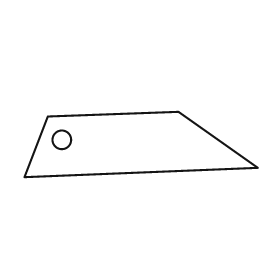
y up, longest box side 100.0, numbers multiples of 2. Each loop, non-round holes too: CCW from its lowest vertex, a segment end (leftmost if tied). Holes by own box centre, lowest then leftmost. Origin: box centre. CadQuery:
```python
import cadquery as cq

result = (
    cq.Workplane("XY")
    .moveTo(-50.0, -14.0)
    .lineTo(50.0, -10.0)
    .lineTo(16.0, 14.0)
    .lineTo(-40.0, 12.0)
    .close()
    .moveTo(-34.0, 2.0)
    .circle(4.0)
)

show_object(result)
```